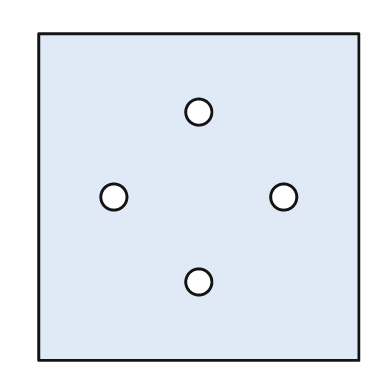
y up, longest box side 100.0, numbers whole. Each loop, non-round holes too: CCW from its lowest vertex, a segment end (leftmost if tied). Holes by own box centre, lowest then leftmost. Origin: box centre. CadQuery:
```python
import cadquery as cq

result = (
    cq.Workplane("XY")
    .moveTo(-49.0, -50.0)
    .lineTo(49.0, -50.0)
    .lineTo(49.0, 50.0)
    .lineTo(-49.0, 50.0)
    .close()
    .moveTo(0.0, -26.0)
    .circle(4.0)
    .moveTo(-26.0, 0.0)
    .circle(4.0)
    .moveTo(26.0, 0.0)
    .circle(4.0)
    .moveTo(0.0, 26.0)
    .circle(4.0)
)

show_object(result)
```